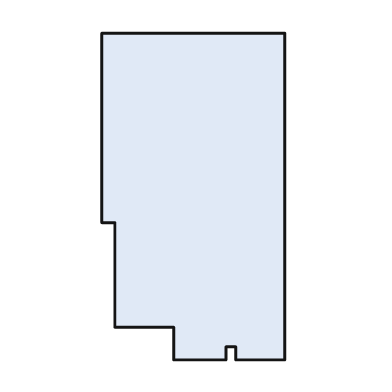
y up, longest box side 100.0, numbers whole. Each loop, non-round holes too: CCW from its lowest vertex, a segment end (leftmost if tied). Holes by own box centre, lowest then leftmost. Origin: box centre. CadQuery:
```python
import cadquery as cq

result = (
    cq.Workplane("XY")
    .moveTo(-6.0, -50.0)
    .lineTo(10.0, -50.0)
    .lineTo(10.0, -46.0)
    .lineTo(13.0, -46.0)
    .lineTo(13.0, -50.0)
    .lineTo(28.0, -50.0)
    .lineTo(28.0, 50.0)
    .lineTo(-28.0, 50.0)
    .lineTo(-28.0, -8.0)
    .lineTo(-24.0, -8.0)
    .lineTo(-24.0, -40.0)
    .lineTo(-6.0, -40.0)
    .close()
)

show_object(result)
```